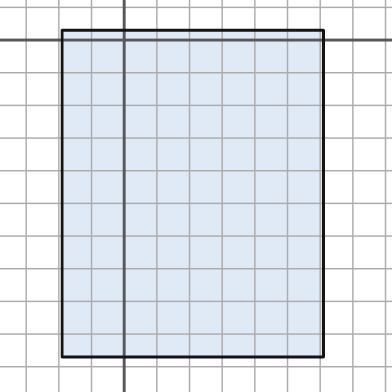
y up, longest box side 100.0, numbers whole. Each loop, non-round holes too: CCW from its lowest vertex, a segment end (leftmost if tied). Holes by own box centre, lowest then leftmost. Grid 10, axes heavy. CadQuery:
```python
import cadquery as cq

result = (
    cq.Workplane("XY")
    .moveTo(-19.0, -97.0)
    .lineTo(61.0, -97.0)
    .lineTo(61.0, 3.0)
    .lineTo(-19.0, 3.0)
    .close()
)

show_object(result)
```